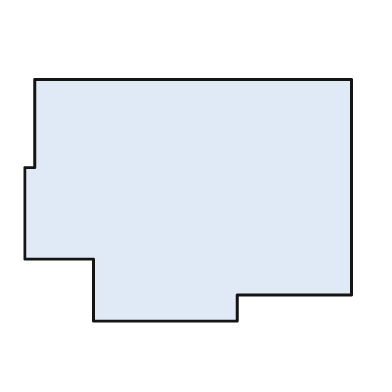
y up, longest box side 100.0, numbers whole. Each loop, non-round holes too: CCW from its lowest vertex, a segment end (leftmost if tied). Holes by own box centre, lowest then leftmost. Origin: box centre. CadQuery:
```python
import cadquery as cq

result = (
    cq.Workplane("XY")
    .moveTo(-29.0, -37.0)
    .lineTo(15.0, -37.0)
    .lineTo(15.0, -29.0)
    .lineTo(50.0, -29.0)
    .lineTo(50.0, 37.0)
    .lineTo(-47.0, 37.0)
    .lineTo(-47.0, 10.0)
    .lineTo(-50.0, 10.0)
    .lineTo(-50.0, -18.0)
    .lineTo(-29.0, -18.0)
    .close()
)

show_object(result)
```